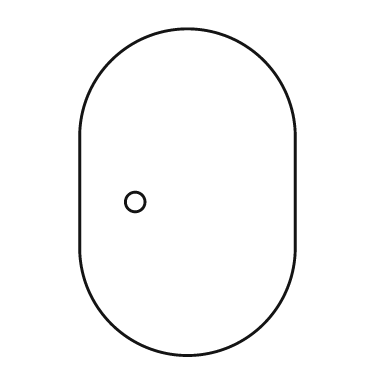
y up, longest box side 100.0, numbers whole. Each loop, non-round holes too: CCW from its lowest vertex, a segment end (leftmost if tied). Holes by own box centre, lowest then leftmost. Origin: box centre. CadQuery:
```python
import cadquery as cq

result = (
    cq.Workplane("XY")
    .moveTo(-33.0, -17.0)
    .threePointArc((0.0, -50.0), (33.0, -17.0))
    .lineTo(33.0, 17.0)
    .threePointArc((0.0, 50.0), (-33.0, 17.0))
    .close()
    .moveTo(-16.0, -3.0)
    .circle(3.0)
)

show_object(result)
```